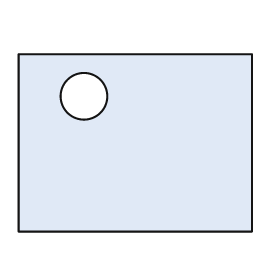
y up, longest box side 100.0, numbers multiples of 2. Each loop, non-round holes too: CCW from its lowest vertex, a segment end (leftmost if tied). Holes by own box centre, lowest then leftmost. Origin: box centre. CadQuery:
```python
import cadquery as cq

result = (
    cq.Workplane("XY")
    .moveTo(-50.0, -38.0)
    .lineTo(50.0, -38.0)
    .lineTo(50.0, 38.0)
    .lineTo(-50.0, 38.0)
    .close()
    .moveTo(-22.0, 20.0)
    .circle(10.0)
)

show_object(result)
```